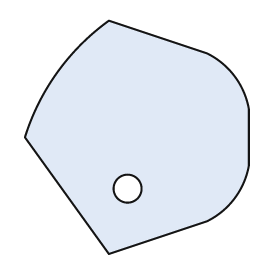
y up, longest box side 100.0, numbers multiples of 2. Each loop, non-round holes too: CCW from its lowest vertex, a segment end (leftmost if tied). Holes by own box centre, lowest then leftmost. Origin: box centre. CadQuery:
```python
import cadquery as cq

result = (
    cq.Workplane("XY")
    .moveTo(-12.0, -50.0)
    .lineTo(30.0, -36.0)
    .threePointArc((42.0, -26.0), (48.0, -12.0))
    .lineTo(48.0, 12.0)
    .threePointArc((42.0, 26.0), (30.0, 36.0))
    .lineTo(-12.0, 50.0)
    .threePointArc((-34.0, 28.0), (-48.0, 0.0))
    .close()
    .moveTo(-4.0, -22.0)
    .circle(6.0)
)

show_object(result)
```